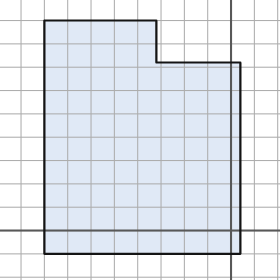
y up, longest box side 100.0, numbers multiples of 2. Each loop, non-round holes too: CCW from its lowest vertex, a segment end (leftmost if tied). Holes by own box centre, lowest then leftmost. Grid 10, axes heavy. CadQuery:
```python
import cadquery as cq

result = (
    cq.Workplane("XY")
    .moveTo(-80.0, -10.0)
    .lineTo(4.0, -10.0)
    .lineTo(4.0, 72.0)
    .lineTo(-32.0, 72.0)
    .lineTo(-32.0, 90.0)
    .lineTo(-80.0, 90.0)
    .close()
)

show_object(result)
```